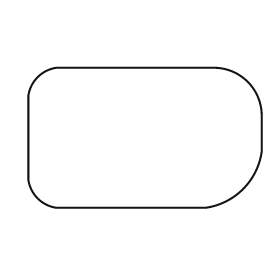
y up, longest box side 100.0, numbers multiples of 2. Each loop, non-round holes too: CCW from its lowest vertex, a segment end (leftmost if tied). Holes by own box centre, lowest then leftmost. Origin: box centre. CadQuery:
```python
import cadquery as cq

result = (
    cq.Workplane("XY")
    .moveTo(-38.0, -30.0)
    .lineTo(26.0, -30.0)
    .threePointArc((42.0, -22.0), (50.0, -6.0))
    .lineTo(50.0, 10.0)
    .threePointArc((44.0, 24.0), (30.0, 30.0))
    .lineTo(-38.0, 30.0)
    .threePointArc((-46.0, 26.0), (-50.0, 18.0))
    .lineTo(-50.0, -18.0)
    .threePointArc((-46.0, -26.0), (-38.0, -30.0))
    .close()
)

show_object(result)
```